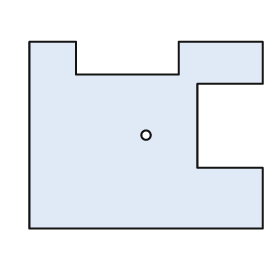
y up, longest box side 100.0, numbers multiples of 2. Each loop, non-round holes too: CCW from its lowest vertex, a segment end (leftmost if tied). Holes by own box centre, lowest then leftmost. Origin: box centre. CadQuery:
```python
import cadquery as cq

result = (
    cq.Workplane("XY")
    .moveTo(-50.0, -40.0)
    .lineTo(50.0, -40.0)
    .lineTo(50.0, -14.0)
    .lineTo(22.0, -14.0)
    .lineTo(22.0, 22.0)
    .lineTo(50.0, 22.0)
    .lineTo(50.0, 40.0)
    .lineTo(14.0, 40.0)
    .lineTo(14.0, 26.0)
    .lineTo(-30.0, 26.0)
    .lineTo(-30.0, 40.0)
    .lineTo(-50.0, 40.0)
    .close()
    .moveTo(0.0, 0.0)
    .circle(2.0)
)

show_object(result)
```